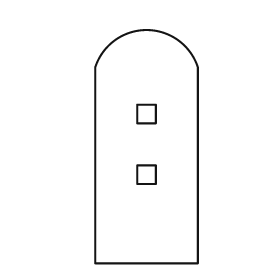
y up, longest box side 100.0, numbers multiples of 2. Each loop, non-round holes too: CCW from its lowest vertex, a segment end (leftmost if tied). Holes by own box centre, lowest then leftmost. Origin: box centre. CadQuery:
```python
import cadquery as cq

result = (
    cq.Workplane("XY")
    .moveTo(-22.0, -50.0)
    .lineTo(22.0, -50.0)
    .lineTo(22.0, 34.0)
    .threePointArc((0.0, 50.0), (-22.0, 34.0))
    .close()
    .moveTo(-4.0, -16.0)
    .lineTo(4.0, -16.0)
    .lineTo(4.0, -8.0)
    .lineTo(-4.0, -8.0)
    .close()
    .moveTo(-4.0, 10.0)
    .lineTo(4.0, 10.0)
    .lineTo(4.0, 18.0)
    .lineTo(-4.0, 18.0)
    .close()
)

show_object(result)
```